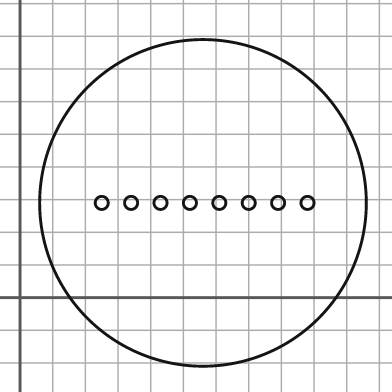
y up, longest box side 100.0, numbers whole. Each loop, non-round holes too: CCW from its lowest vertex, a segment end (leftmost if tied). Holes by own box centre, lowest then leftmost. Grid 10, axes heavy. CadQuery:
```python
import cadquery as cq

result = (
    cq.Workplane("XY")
    .moveTo(56.0, 29.0)
    .circle(50.0)
    .moveTo(25.0, 29.0)
    .circle(2.0)
    .moveTo(34.0, 29.0)
    .circle(2.0)
    .moveTo(43.0, 29.0)
    .circle(2.0)
    .moveTo(52.0, 29.0)
    .circle(2.0)
    .moveTo(61.0, 29.0)
    .circle(2.0)
    .moveTo(70.0, 29.0)
    .circle(2.0)
    .moveTo(79.0, 29.0)
    .circle(2.0)
    .moveTo(88.0, 29.0)
    .circle(2.0)
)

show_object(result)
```